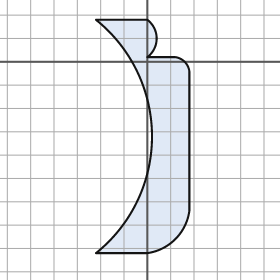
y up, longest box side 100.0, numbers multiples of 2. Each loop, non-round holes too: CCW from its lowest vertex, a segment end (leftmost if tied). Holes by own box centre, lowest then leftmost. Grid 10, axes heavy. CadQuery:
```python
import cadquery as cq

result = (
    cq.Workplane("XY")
    .moveTo(-22.0, -82.0)
    .lineTo(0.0, -82.0)
    .threePointArc((12.0, -76.0), (18.0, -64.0))
    .lineTo(18.0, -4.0)
    .threePointArc((16.0, 0.0), (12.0, 2.0))
    .lineTo(0.0, 2.0)
    .threePointArc((4.0, 10.0), (0.0, 18.0))
    .lineTo(-22.0, 18.0)
    .threePointArc((2.0, -32.0), (-22.0, -82.0))
    .close()
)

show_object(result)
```